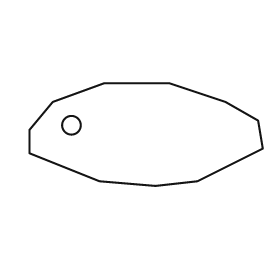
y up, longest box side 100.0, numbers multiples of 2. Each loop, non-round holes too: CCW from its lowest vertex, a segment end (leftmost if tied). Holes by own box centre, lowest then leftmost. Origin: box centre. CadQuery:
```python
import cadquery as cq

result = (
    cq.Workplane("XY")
    .moveTo(4.0, -22.0)
    .lineTo(22.0, -20.0)
    .lineTo(50.0, -6.0)
    .lineTo(48.0, 6.0)
    .lineTo(34.0, 14.0)
    .lineTo(10.0, 22.0)
    .lineTo(-18.0, 22.0)
    .lineTo(-40.0, 14.0)
    .lineTo(-50.0, 2.0)
    .lineTo(-50.0, -8.0)
    .lineTo(-20.0, -20.0)
    .close()
    .moveTo(-32.0, 4.0)
    .circle(4.0)
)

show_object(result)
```